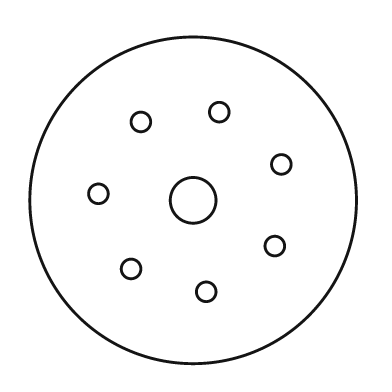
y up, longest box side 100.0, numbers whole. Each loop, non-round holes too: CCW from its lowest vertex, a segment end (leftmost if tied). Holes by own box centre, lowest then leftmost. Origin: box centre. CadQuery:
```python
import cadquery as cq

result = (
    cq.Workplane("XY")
    .moveTo(0.0, 0.0)
    .circle(50.0)
    .moveTo(4.0, -28.0)
    .circle(3.0)
    .moveTo(-19.0, -21.0)
    .circle(3.0)
    .moveTo(25.0, -14.0)
    .circle(3.0)
    .moveTo(0.0, 0.0)
    .circle(7.0)
    .moveTo(-29.0, 2.0)
    .circle(3.0)
    .moveTo(27.0, 11.0)
    .circle(3.0)
    .moveTo(-16.0, 24.0)
    .circle(3.0)
    .moveTo(8.0, 27.0)
    .circle(3.0)
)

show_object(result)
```